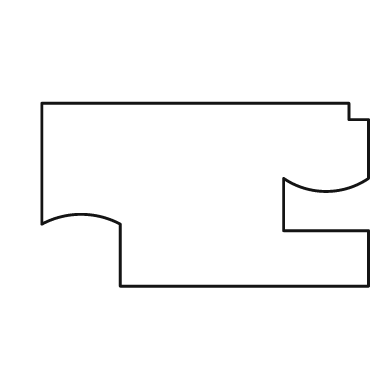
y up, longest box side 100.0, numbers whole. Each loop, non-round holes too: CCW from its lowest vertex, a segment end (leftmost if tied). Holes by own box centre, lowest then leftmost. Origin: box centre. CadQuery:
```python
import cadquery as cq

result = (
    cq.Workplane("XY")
    .moveTo(-26.0, -28.0)
    .lineTo(50.0, -28.0)
    .lineTo(50.0, -11.0)
    .lineTo(24.0, -11.0)
    .lineTo(24.0, 5.0)
    .threePointArc((37.0, 1.0), (50.0, 5.0))
    .lineTo(50.0, 23.0)
    .lineTo(44.0, 23.0)
    .lineTo(44.0, 28.0)
    .lineTo(-50.0, 28.0)
    .lineTo(-50.0, -9.0)
    .threePointArc((-38.0, -6.0), (-26.0, -9.0))
    .close()
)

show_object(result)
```